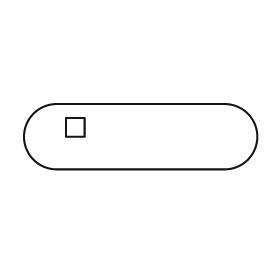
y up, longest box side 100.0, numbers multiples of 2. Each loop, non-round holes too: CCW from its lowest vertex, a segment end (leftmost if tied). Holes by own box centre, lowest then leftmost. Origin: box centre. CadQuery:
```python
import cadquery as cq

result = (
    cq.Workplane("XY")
    .moveTo(-36.0, -14.0)
    .lineTo(36.0, -14.0)
    .threePointArc((50.0, 0.0), (36.0, 14.0))
    .lineTo(-36.0, 14.0)
    .threePointArc((-50.0, 0.0), (-36.0, -14.0))
    .close()
    .moveTo(-32.0, 0.0)
    .lineTo(-24.0, 0.0)
    .lineTo(-24.0, 8.0)
    .lineTo(-32.0, 8.0)
    .close()
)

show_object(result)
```